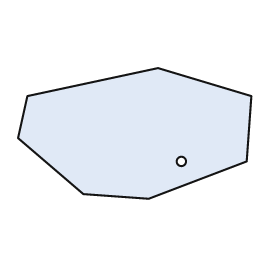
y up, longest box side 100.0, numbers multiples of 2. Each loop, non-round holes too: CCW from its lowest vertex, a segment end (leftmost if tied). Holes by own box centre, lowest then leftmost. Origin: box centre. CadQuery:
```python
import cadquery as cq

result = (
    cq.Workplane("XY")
    .moveTo(6.0, -28.0)
    .lineTo(48.0, -12.0)
    .lineTo(50.0, 16.0)
    .lineTo(10.0, 28.0)
    .lineTo(-46.0, 16.0)
    .lineTo(-50.0, -2.0)
    .lineTo(-22.0, -26.0)
    .close()
    .moveTo(20.0, -12.0)
    .circle(2.0)
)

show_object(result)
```